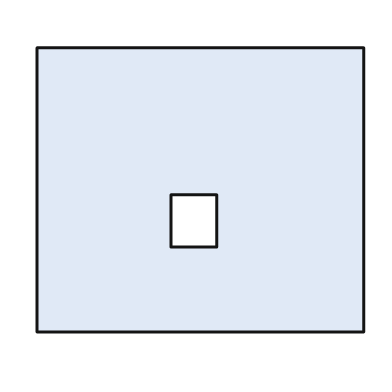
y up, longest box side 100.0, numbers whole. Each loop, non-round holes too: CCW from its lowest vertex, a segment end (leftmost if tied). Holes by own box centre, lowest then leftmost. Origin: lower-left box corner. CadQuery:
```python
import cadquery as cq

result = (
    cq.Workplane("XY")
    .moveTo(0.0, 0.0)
    .lineTo(100.0, 0.0)
    .lineTo(100.0, 87.0)
    .lineTo(0.0, 87.0)
    .close()
    .moveTo(41.0, 26.0)
    .lineTo(55.0, 26.0)
    .lineTo(55.0, 42.0)
    .lineTo(41.0, 42.0)
    .close()
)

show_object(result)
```